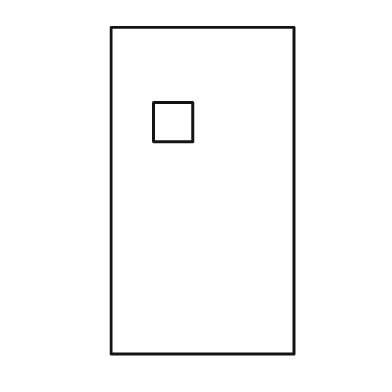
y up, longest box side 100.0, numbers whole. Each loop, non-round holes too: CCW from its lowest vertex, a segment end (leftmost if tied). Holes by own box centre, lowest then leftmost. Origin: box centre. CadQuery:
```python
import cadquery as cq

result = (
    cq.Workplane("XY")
    .moveTo(-28.0, -50.0)
    .lineTo(28.0, -50.0)
    .lineTo(28.0, 50.0)
    .lineTo(-28.0, 50.0)
    .close()
    .moveTo(-15.0, 15.0)
    .lineTo(-3.0, 15.0)
    .lineTo(-3.0, 27.0)
    .lineTo(-15.0, 27.0)
    .close()
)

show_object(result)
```